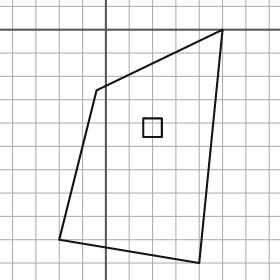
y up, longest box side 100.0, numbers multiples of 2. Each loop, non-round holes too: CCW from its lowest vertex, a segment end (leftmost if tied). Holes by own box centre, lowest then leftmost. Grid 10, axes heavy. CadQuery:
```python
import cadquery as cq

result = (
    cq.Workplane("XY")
    .moveTo(40.0, -100.0)
    .lineTo(50.0, 0.0)
    .lineTo(-4.0, -26.0)
    .lineTo(-20.0, -90.0)
    .close()
    .moveTo(16.0, -46.0)
    .lineTo(24.0, -46.0)
    .lineTo(24.0, -38.0)
    .lineTo(16.0, -38.0)
    .close()
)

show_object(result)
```